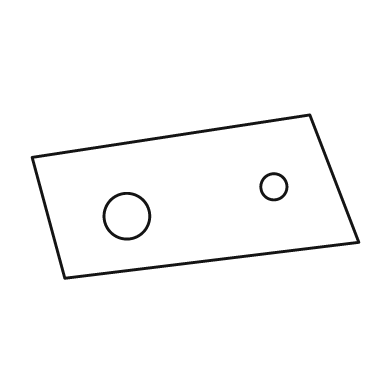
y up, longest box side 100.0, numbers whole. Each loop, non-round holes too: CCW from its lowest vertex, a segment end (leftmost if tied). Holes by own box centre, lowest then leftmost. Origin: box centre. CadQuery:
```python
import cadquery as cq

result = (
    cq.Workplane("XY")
    .moveTo(-40.0, -25.0)
    .lineTo(50.0, -14.0)
    .lineTo(35.0, 25.0)
    .lineTo(-50.0, 12.0)
    .close()
    .moveTo(-21.0, -6.0)
    .circle(7.0)
    .moveTo(24.0, 3.0)
    .circle(4.0)
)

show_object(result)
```